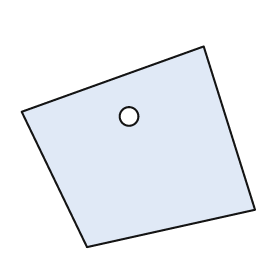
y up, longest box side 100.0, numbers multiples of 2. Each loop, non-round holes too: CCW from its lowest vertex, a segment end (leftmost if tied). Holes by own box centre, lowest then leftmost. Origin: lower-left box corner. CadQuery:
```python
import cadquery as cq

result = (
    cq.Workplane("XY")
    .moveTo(28.0, 0.0)
    .lineTo(100.0, 16.0)
    .lineTo(78.0, 86.0)
    .lineTo(0.0, 58.0)
    .close()
    .moveTo(46.0, 56.0)
    .circle(4.0)
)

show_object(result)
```